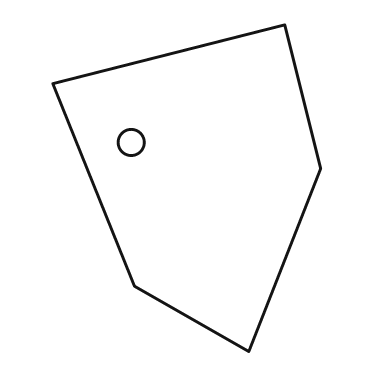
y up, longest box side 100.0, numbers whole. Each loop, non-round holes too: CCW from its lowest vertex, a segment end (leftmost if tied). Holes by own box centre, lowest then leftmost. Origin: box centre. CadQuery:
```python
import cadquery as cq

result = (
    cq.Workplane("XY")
    .moveTo(19.0, -50.0)
    .lineTo(41.0, 6.0)
    .lineTo(30.0, 50.0)
    .lineTo(-41.0, 32.0)
    .lineTo(-16.0, -30.0)
    .close()
    .moveTo(-17.0, 14.0)
    .circle(4.0)
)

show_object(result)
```